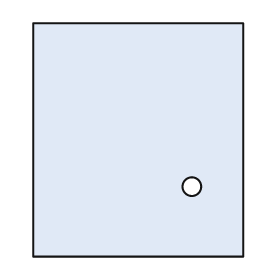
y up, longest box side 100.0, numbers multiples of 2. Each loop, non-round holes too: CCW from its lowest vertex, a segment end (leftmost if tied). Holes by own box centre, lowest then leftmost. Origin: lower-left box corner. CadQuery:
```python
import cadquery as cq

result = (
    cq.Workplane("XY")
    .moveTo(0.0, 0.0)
    .lineTo(90.0, 0.0)
    .lineTo(90.0, 100.0)
    .lineTo(0.0, 100.0)
    .close()
    .moveTo(68.0, 30.0)
    .circle(4.0)
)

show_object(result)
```